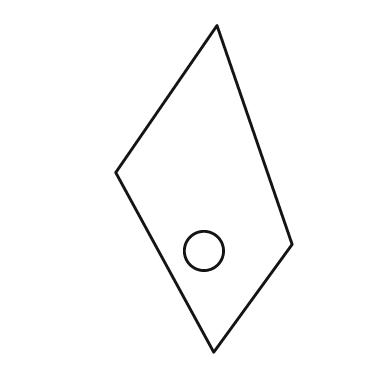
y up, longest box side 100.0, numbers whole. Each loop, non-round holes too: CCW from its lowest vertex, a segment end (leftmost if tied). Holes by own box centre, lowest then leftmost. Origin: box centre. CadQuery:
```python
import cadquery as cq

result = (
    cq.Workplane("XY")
    .moveTo(3.0, -50.0)
    .lineTo(27.0, -17.0)
    .lineTo(4.0, 50.0)
    .lineTo(-27.0, 5.0)
    .close()
    .moveTo(0.0, -19.0)
    .circle(6.0)
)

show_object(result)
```